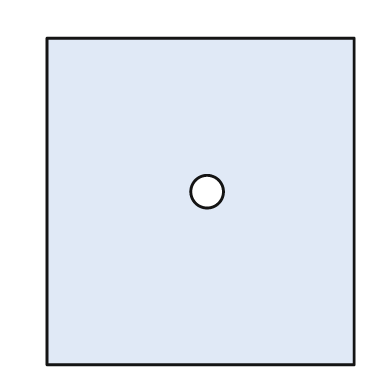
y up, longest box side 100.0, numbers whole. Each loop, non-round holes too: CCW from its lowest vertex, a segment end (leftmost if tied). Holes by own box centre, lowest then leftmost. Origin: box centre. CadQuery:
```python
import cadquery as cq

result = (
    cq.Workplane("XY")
    .moveTo(-47.0, -50.0)
    .lineTo(47.0, -50.0)
    .lineTo(47.0, 50.0)
    .lineTo(-47.0, 50.0)
    .close()
    .moveTo(2.0, 3.0)
    .circle(5.0)
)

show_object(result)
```